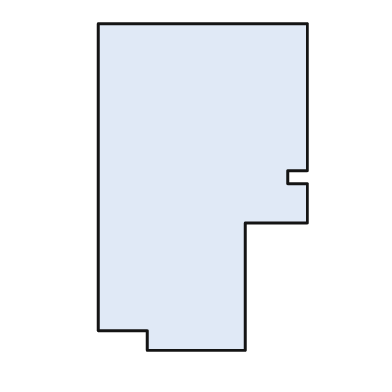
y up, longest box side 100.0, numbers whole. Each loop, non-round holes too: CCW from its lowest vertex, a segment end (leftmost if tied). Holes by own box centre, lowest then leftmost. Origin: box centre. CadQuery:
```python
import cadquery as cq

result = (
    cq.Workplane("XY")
    .moveTo(-17.0, -50.0)
    .lineTo(13.0, -50.0)
    .lineTo(13.0, -11.0)
    .lineTo(32.0, -11.0)
    .lineTo(32.0, 1.0)
    .lineTo(26.0, 1.0)
    .lineTo(26.0, 5.0)
    .lineTo(32.0, 5.0)
    .lineTo(32.0, 50.0)
    .lineTo(-32.0, 50.0)
    .lineTo(-32.0, -44.0)
    .lineTo(-17.0, -44.0)
    .close()
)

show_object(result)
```